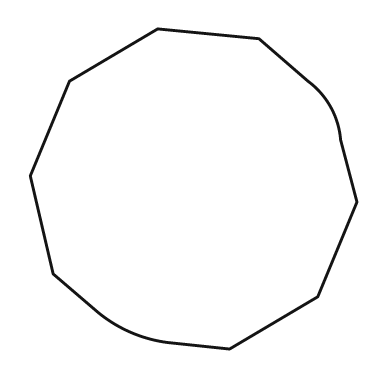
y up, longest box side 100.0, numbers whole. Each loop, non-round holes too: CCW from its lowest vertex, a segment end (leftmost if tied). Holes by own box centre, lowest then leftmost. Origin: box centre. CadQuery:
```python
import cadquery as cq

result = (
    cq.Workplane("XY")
    .moveTo(11.0, -49.0)
    .lineTo(38.0, -33.0)
    .lineTo(50.0, -4.0)
    .lineTo(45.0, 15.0)
    .threePointArc((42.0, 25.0), (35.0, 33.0))
    .lineTo(20.0, 46.0)
    .lineTo(-11.0, 49.0)
    .lineTo(-38.0, 33.0)
    .lineTo(-50.0, 4.0)
    .lineTo(-43.0, -26.0)
    .lineTo(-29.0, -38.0)
    .threePointArc((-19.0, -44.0), (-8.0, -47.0))
    .close()
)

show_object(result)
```